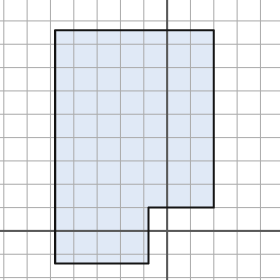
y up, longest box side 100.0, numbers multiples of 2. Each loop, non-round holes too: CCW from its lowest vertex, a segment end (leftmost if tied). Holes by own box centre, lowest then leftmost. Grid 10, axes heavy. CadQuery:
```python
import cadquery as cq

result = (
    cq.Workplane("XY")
    .moveTo(-48.0, -14.0)
    .lineTo(-8.0, -14.0)
    .lineTo(-8.0, 10.0)
    .lineTo(20.0, 10.0)
    .lineTo(20.0, 86.0)
    .lineTo(-48.0, 86.0)
    .close()
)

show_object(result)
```